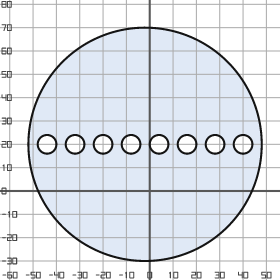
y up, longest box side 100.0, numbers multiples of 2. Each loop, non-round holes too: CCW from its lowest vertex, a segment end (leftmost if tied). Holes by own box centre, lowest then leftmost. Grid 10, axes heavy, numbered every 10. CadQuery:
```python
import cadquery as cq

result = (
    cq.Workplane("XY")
    .moveTo(-2.0, 20.0)
    .circle(50.0)
    .moveTo(-44.0, 20.0)
    .circle(4.0)
    .moveTo(-32.0, 20.0)
    .circle(4.0)
    .moveTo(-20.0, 20.0)
    .circle(4.0)
    .moveTo(-8.0, 20.0)
    .circle(4.0)
    .moveTo(4.0, 20.0)
    .circle(4.0)
    .moveTo(16.0, 20.0)
    .circle(4.0)
    .moveTo(28.0, 20.0)
    .circle(4.0)
    .moveTo(40.0, 20.0)
    .circle(4.0)
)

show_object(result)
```